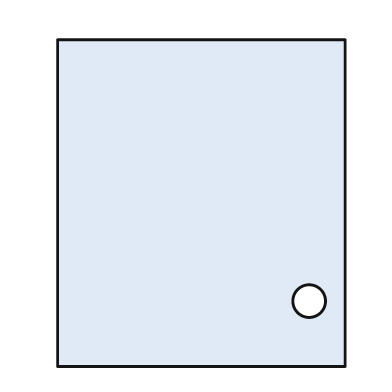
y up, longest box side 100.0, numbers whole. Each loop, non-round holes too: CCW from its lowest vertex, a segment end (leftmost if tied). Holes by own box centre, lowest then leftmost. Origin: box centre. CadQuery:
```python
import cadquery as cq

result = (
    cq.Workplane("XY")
    .moveTo(-44.0, -50.0)
    .lineTo(44.0, -50.0)
    .lineTo(44.0, 50.0)
    .lineTo(-44.0, 50.0)
    .close()
    .moveTo(33.0, -30.0)
    .circle(5.0)
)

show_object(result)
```